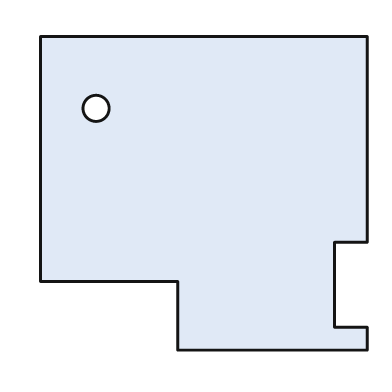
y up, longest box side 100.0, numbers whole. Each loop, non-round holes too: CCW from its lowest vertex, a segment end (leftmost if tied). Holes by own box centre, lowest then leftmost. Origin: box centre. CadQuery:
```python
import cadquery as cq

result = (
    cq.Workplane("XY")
    .moveTo(-8.0, -48.0)
    .lineTo(50.0, -48.0)
    .lineTo(50.0, -41.0)
    .lineTo(40.0, -41.0)
    .lineTo(40.0, -15.0)
    .lineTo(50.0, -15.0)
    .lineTo(50.0, 48.0)
    .lineTo(-50.0, 48.0)
    .lineTo(-50.0, -27.0)
    .lineTo(-8.0, -27.0)
    .close()
    .moveTo(-33.0, 26.0)
    .circle(4.0)
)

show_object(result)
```